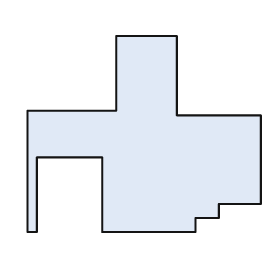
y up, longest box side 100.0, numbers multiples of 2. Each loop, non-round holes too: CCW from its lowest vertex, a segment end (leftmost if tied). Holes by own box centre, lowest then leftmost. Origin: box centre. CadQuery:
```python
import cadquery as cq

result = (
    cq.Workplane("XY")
    .moveTo(-50.0, -42.0)
    .lineTo(-46.0, -42.0)
    .lineTo(-46.0, -10.0)
    .lineTo(-18.0, -10.0)
    .lineTo(-18.0, -42.0)
    .lineTo(22.0, -42.0)
    .lineTo(22.0, -36.0)
    .lineTo(32.0, -36.0)
    .lineTo(32.0, -30.0)
    .lineTo(50.0, -30.0)
    .lineTo(50.0, 8.0)
    .lineTo(14.0, 8.0)
    .lineTo(14.0, 42.0)
    .lineTo(-12.0, 42.0)
    .lineTo(-12.0, 10.0)
    .lineTo(-50.0, 10.0)
    .close()
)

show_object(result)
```